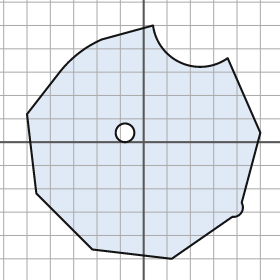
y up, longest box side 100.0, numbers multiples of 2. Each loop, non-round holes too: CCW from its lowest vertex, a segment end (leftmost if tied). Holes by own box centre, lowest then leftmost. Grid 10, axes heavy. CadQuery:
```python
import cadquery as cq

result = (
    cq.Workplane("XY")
    .moveTo(12.0, -50.0)
    .lineTo(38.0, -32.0)
    .threePointArc((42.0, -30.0), (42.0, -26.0))
    .lineTo(50.0, 4.0)
    .lineTo(36.0, 36.0)
    .threePointArc((16.0, 34.0), (4.0, 50.0))
    .lineTo(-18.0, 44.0)
    .threePointArc((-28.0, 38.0), (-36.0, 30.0))
    .lineTo(-50.0, 12.0)
    .lineTo(-46.0, -22.0)
    .lineTo(-22.0, -46.0)
    .close()
    .moveTo(-8.0, 4.0)
    .circle(4.0)
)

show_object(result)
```